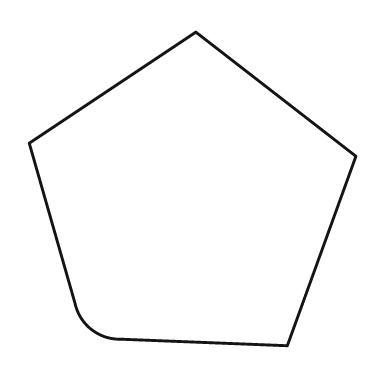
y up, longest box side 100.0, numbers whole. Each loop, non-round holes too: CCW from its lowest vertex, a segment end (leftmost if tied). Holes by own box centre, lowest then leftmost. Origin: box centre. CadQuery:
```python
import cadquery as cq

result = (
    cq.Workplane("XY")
    .moveTo(29.0, -48.0)
    .lineTo(50.0, 10.0)
    .lineTo(1.0, 48.0)
    .lineTo(-50.0, 14.0)
    .lineTo(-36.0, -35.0)
    .threePointArc((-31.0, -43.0), (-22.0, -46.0))
    .close()
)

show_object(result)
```